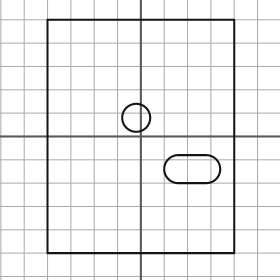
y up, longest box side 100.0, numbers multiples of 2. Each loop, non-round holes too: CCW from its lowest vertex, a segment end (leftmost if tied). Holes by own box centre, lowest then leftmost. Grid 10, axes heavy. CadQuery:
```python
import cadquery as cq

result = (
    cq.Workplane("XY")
    .moveTo(-40.0, -50.0)
    .lineTo(40.0, -50.0)
    .lineTo(40.0, 50.0)
    .lineTo(-40.0, 50.0)
    .close()
    .moveTo(16.0, -20.0)
    .lineTo(28.0, -20.0)
    .threePointArc((34.0, -14.0), (28.0, -8.0))
    .lineTo(16.0, -8.0)
    .threePointArc((10.0, -14.0), (16.0, -20.0))
    .close()
    .moveTo(-2.0, 8.0)
    .circle(6.0)
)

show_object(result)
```